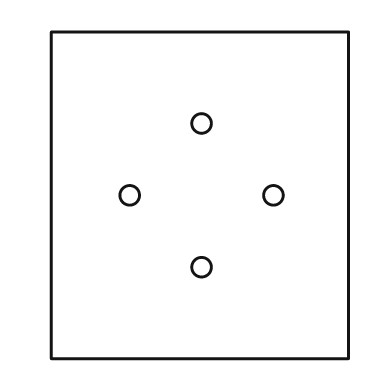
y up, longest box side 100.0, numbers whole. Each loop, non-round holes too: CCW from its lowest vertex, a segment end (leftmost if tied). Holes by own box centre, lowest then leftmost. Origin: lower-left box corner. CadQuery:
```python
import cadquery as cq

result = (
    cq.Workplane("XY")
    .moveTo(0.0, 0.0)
    .lineTo(91.0, 0.0)
    .lineTo(91.0, 100.0)
    .lineTo(0.0, 100.0)
    .close()
    .moveTo(46.0, 28.0)
    .circle(3.0)
    .moveTo(24.0, 50.0)
    .circle(3.0)
    .moveTo(68.0, 50.0)
    .circle(3.0)
    .moveTo(46.0, 72.0)
    .circle(3.0)
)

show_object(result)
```